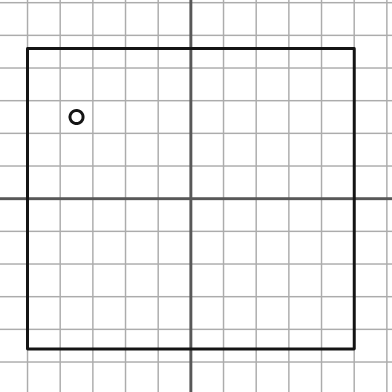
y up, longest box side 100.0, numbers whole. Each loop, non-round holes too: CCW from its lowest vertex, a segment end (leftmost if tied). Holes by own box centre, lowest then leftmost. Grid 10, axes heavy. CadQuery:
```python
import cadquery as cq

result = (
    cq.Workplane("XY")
    .moveTo(-50.0, -46.0)
    .lineTo(50.0, -46.0)
    .lineTo(50.0, 46.0)
    .lineTo(-50.0, 46.0)
    .close()
    .moveTo(-35.0, 25.0)
    .circle(2.0)
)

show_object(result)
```